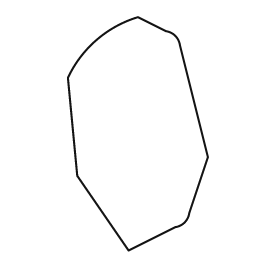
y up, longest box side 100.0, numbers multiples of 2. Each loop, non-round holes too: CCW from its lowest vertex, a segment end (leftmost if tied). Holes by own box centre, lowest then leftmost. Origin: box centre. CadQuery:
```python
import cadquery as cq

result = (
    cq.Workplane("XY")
    .moveTo(-4.0, -50.0)
    .lineTo(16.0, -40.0)
    .threePointArc((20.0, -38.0), (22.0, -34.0))
    .lineTo(30.0, -10.0)
    .lineTo(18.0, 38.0)
    .threePointArc((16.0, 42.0), (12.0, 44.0))
    .lineTo(0.0, 50.0)
    .threePointArc((-18.0, 40.0), (-30.0, 24.0))
    .lineTo(-26.0, -18.0)
    .close()
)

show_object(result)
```